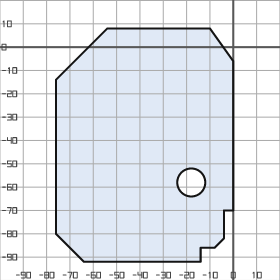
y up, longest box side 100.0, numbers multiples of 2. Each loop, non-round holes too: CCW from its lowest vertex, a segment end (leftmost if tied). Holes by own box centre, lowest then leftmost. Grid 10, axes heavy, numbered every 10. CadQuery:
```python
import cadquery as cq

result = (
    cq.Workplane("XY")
    .moveTo(-64.0, -92.0)
    .lineTo(-14.0, -92.0)
    .lineTo(-14.0, -86.0)
    .lineTo(-8.0, -86.0)
    .lineTo(-4.0, -82.0)
    .lineTo(-4.0, -70.0)
    .lineTo(0.0, -70.0)
    .lineTo(0.0, -6.0)
    .lineTo(-10.0, 8.0)
    .lineTo(-54.0, 8.0)
    .lineTo(-76.0, -14.0)
    .lineTo(-76.0, -80.0)
    .close()
    .moveTo(-18.0, -58.0)
    .circle(6.0)
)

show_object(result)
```